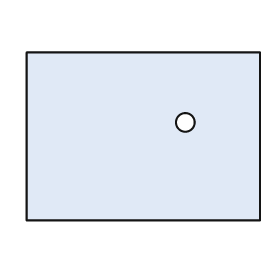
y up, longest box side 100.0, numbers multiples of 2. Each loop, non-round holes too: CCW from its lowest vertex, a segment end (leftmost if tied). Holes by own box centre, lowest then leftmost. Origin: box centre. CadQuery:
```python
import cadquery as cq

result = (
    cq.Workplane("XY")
    .moveTo(-50.0, -36.0)
    .lineTo(50.0, -36.0)
    .lineTo(50.0, 36.0)
    .lineTo(-50.0, 36.0)
    .close()
    .moveTo(18.0, 6.0)
    .circle(4.0)
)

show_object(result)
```